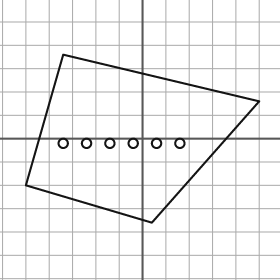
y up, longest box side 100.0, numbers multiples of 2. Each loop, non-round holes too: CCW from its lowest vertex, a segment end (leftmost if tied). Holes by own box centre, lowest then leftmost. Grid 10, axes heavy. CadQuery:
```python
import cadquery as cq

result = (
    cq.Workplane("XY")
    .moveTo(4.0, -36.0)
    .lineTo(50.0, 16.0)
    .lineTo(-34.0, 36.0)
    .lineTo(-50.0, -20.0)
    .close()
    .moveTo(-34.0, -2.0)
    .circle(2.0)
    .moveTo(-24.0, -2.0)
    .circle(2.0)
    .moveTo(-14.0, -2.0)
    .circle(2.0)
    .moveTo(-4.0, -2.0)
    .circle(2.0)
    .moveTo(6.0, -2.0)
    .circle(2.0)
    .moveTo(16.0, -2.0)
    .circle(2.0)
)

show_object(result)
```